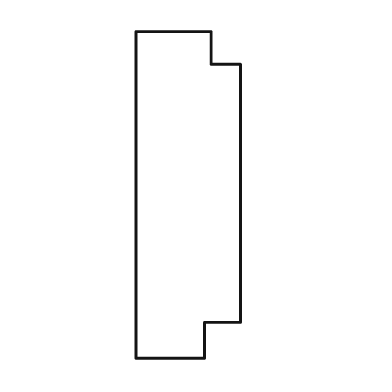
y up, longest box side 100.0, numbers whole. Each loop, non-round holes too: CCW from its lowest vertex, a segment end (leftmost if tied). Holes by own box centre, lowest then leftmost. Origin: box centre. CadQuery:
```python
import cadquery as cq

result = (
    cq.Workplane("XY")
    .moveTo(-16.0, -50.0)
    .lineTo(5.0, -50.0)
    .lineTo(5.0, -39.0)
    .lineTo(16.0, -39.0)
    .lineTo(16.0, 40.0)
    .lineTo(7.0, 40.0)
    .lineTo(7.0, 50.0)
    .lineTo(-16.0, 50.0)
    .close()
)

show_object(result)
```